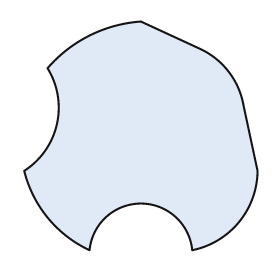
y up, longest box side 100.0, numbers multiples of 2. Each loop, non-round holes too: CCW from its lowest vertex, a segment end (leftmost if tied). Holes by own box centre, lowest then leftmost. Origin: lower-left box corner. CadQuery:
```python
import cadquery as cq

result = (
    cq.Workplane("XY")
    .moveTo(28.0, 0.0)
    .threePointArc((50.0, 20.0), (72.0, 0.0))
    .threePointArc((92.0, 12.0), (100.0, 34.0))
    .lineTo(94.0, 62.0)
    .threePointArc((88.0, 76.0), (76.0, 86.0))
    .lineTo(50.0, 98.0)
    .threePointArc((28.0, 92.0), (10.0, 78.0))
    .threePointArc((14.0, 54.0), (0.0, 34.0))
    .threePointArc((10.0, 14.0), (28.0, 0.0))
    .close()
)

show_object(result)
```